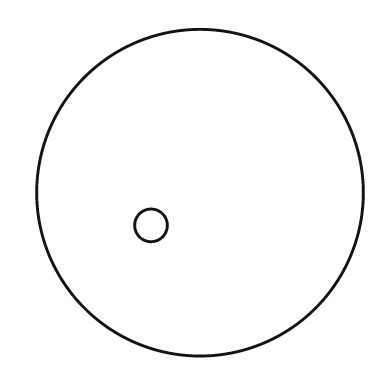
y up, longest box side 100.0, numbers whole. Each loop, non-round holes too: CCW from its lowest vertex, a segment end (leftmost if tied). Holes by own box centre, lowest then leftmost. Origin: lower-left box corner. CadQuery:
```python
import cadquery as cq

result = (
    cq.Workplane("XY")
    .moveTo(50.0, 50.0)
    .circle(50.0)
    .moveTo(35.0, 40.0)
    .circle(5.0)
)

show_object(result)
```